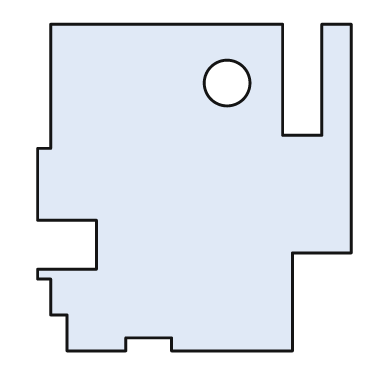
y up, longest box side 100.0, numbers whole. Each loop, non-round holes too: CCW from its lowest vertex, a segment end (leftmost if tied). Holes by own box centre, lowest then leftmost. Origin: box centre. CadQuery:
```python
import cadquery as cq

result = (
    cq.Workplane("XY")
    .moveTo(-39.0, -50.0)
    .lineTo(-21.0, -50.0)
    .lineTo(-21.0, -46.0)
    .lineTo(-7.0, -46.0)
    .lineTo(-7.0, -50.0)
    .lineTo(30.0, -50.0)
    .lineTo(30.0, -20.0)
    .lineTo(48.0, -20.0)
    .lineTo(48.0, 50.0)
    .lineTo(39.0, 50.0)
    .lineTo(39.0, 16.0)
    .lineTo(27.0, 16.0)
    .lineTo(27.0, 50.0)
    .lineTo(-44.0, 50.0)
    .lineTo(-44.0, 12.0)
    .lineTo(-48.0, 12.0)
    .lineTo(-48.0, -10.0)
    .lineTo(-30.0, -10.0)
    .lineTo(-30.0, -25.0)
    .lineTo(-48.0, -25.0)
    .lineTo(-48.0, -28.0)
    .lineTo(-44.0, -28.0)
    .lineTo(-44.0, -39.0)
    .lineTo(-39.0, -39.0)
    .close()
    .moveTo(10.0, 32.0)
    .circle(7.0)
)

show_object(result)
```